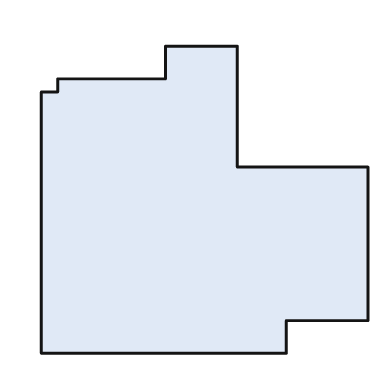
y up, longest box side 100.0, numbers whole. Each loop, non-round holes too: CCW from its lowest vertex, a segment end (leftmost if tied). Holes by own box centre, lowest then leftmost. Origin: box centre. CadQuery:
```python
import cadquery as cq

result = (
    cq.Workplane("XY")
    .moveTo(-50.0, -47.0)
    .lineTo(25.0, -47.0)
    .lineTo(25.0, -37.0)
    .lineTo(50.0, -37.0)
    .lineTo(50.0, 10.0)
    .lineTo(10.0, 10.0)
    .lineTo(10.0, 47.0)
    .lineTo(-12.0, 47.0)
    .lineTo(-12.0, 37.0)
    .lineTo(-45.0, 37.0)
    .lineTo(-45.0, 33.0)
    .lineTo(-50.0, 33.0)
    .close()
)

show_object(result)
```